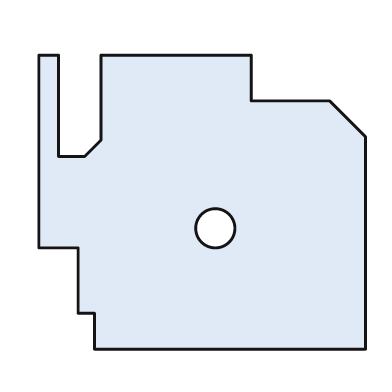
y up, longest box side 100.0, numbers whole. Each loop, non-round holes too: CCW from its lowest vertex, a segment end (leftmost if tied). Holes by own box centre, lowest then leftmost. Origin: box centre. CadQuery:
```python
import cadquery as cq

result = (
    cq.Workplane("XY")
    .moveTo(-33.0, -45.0)
    .lineTo(50.0, -45.0)
    .lineTo(50.0, 20.0)
    .lineTo(39.0, 31.0)
    .lineTo(15.0, 31.0)
    .lineTo(15.0, 45.0)
    .lineTo(-31.0, 45.0)
    .lineTo(-31.0, 19.0)
    .lineTo(-36.0, 14.0)
    .lineTo(-44.0, 14.0)
    .lineTo(-44.0, 45.0)
    .lineTo(-50.0, 45.0)
    .lineTo(-50.0, -14.0)
    .lineTo(-38.0, -14.0)
    .lineTo(-38.0, -34.0)
    .lineTo(-33.0, -34.0)
    .close()
    .moveTo(4.0, -8.0)
    .circle(6.0)
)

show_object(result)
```